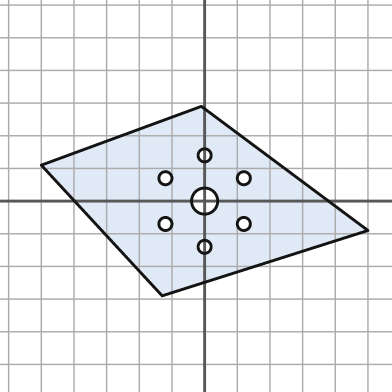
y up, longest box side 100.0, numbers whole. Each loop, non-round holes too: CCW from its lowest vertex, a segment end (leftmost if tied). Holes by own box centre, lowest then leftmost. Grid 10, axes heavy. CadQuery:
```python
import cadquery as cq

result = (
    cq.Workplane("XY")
    .moveTo(-13.0, -29.0)
    .lineTo(50.0, -9.0)
    .lineTo(-1.0, 29.0)
    .lineTo(-50.0, 11.0)
    .close()
    .moveTo(0.0, -14.0)
    .circle(2.0)
    .moveTo(-12.0, -7.0)
    .circle(2.0)
    .moveTo(12.0, -7.0)
    .circle(2.0)
    .moveTo(0.0, 0.0)
    .circle(4.0)
    .moveTo(-12.0, 7.0)
    .circle(2.0)
    .moveTo(12.0, 7.0)
    .circle(2.0)
    .moveTo(0.0, 14.0)
    .circle(2.0)
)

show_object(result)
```